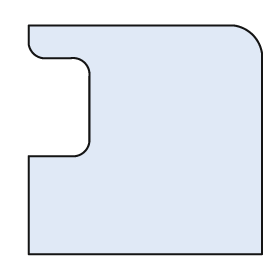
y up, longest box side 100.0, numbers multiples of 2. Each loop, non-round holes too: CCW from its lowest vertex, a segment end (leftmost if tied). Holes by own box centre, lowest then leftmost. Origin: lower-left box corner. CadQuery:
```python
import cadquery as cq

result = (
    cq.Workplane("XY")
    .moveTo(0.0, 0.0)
    .lineTo(100.0, 0.0)
    .lineTo(100.0, 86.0)
    .threePointArc((96.0, 94.0), (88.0, 98.0))
    .lineTo(0.0, 98.0)
    .lineTo(0.0, 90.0)
    .threePointArc((2.0, 86.0), (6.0, 84.0))
    .lineTo(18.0, 84.0)
    .threePointArc((24.0, 82.0), (26.0, 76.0))
    .lineTo(26.0, 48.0)
    .threePointArc((24.0, 44.0), (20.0, 42.0))
    .lineTo(0.0, 42.0)
    .close()
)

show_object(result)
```